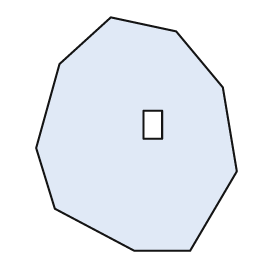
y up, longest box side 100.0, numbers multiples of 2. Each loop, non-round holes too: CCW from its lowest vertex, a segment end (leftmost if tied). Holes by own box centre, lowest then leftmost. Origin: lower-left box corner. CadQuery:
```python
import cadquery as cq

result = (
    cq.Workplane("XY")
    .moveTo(42.0, 0.0)
    .lineTo(66.0, 0.0)
    .lineTo(86.0, 34.0)
    .lineTo(80.0, 70.0)
    .lineTo(60.0, 94.0)
    .lineTo(32.0, 100.0)
    .lineTo(10.0, 80.0)
    .lineTo(0.0, 44.0)
    .lineTo(8.0, 18.0)
    .close()
    .moveTo(46.0, 48.0)
    .lineTo(54.0, 48.0)
    .lineTo(54.0, 60.0)
    .lineTo(46.0, 60.0)
    .close()
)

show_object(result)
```